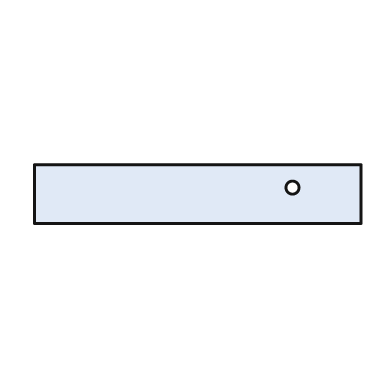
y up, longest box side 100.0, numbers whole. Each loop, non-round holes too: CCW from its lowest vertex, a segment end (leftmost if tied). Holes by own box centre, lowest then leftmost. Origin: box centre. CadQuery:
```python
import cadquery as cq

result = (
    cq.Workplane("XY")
    .moveTo(-50.0, -9.0)
    .lineTo(50.0, -9.0)
    .lineTo(50.0, 9.0)
    .lineTo(-50.0, 9.0)
    .close()
    .moveTo(29.0, 2.0)
    .circle(2.0)
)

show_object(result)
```